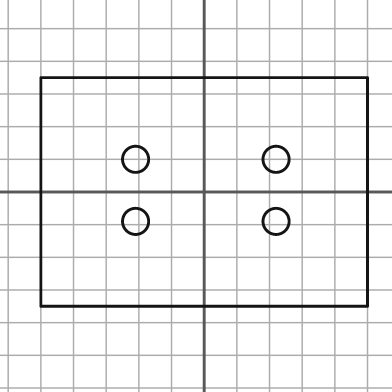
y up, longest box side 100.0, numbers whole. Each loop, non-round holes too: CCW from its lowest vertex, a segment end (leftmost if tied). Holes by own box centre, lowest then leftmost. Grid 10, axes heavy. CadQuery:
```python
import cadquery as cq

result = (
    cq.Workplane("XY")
    .moveTo(-50.0, -35.0)
    .lineTo(50.0, -35.0)
    .lineTo(50.0, 35.0)
    .lineTo(-50.0, 35.0)
    .close()
    .moveTo(-21.0, -9.0)
    .circle(4.0)
    .moveTo(22.0, -9.0)
    .circle(4.0)
    .moveTo(-21.0, 10.0)
    .circle(4.0)
    .moveTo(22.0, 10.0)
    .circle(4.0)
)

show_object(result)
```